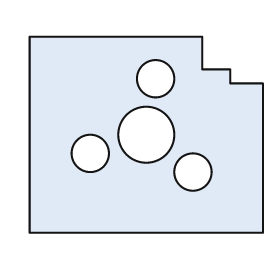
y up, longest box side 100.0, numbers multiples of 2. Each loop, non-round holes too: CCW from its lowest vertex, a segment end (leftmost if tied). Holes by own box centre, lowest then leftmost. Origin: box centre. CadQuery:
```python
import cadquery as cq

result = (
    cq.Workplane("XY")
    .moveTo(-50.0, -42.0)
    .lineTo(50.0, -42.0)
    .lineTo(50.0, 22.0)
    .lineTo(36.0, 22.0)
    .lineTo(36.0, 28.0)
    .lineTo(24.0, 28.0)
    .lineTo(24.0, 42.0)
    .lineTo(-50.0, 42.0)
    .close()
    .moveTo(20.0, -16.0)
    .circle(8.0)
    .moveTo(-24.0, -8.0)
    .circle(8.0)
    .moveTo(0.0, 0.0)
    .circle(12.0)
    .moveTo(4.0, 24.0)
    .circle(8.0)
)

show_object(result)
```